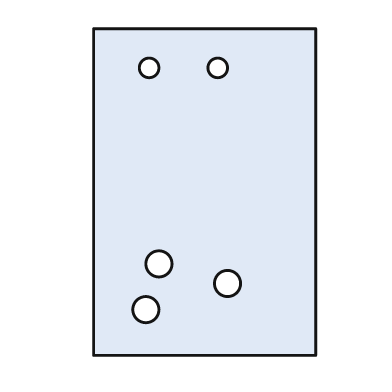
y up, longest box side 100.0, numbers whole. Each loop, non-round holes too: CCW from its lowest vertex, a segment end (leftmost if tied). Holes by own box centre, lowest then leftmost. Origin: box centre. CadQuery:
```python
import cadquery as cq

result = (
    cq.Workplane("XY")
    .moveTo(-34.0, -50.0)
    .lineTo(34.0, -50.0)
    .lineTo(34.0, 50.0)
    .lineTo(-34.0, 50.0)
    .close()
    .moveTo(-18.0, -36.0)
    .circle(4.0)
    .moveTo(7.0, -28.0)
    .circle(4.0)
    .moveTo(-14.0, -22.0)
    .circle(4.0)
    .moveTo(-17.0, 38.0)
    .circle(3.0)
    .moveTo(4.0, 38.0)
    .circle(3.0)
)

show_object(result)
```